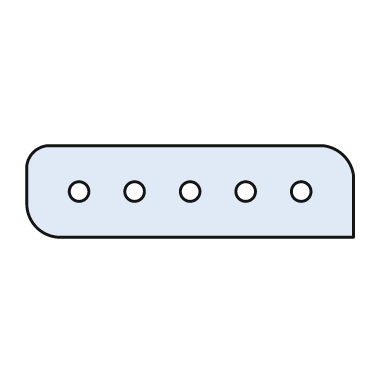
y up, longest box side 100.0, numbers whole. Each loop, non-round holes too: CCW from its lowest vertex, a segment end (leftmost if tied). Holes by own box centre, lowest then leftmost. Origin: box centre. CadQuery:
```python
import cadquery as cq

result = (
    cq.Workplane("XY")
    .moveTo(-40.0, -14.0)
    .lineTo(50.0, -14.0)
    .lineTo(50.0, 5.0)
    .threePointArc((47.0, 11.0), (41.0, 14.0))
    .lineTo(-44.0, 14.0)
    .threePointArc((-48.0, 12.0), (-50.0, 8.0))
    .lineTo(-50.0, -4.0)
    .threePointArc((-47.0, -11.0), (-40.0, -14.0))
    .close()
    .moveTo(-34.0, 0.0)
    .circle(3.0)
    .moveTo(-17.0, 0.0)
    .circle(3.0)
    .moveTo(0.0, 0.0)
    .circle(3.0)
    .moveTo(17.0, 0.0)
    .circle(3.0)
    .moveTo(34.0, 0.0)
    .circle(3.0)
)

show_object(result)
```